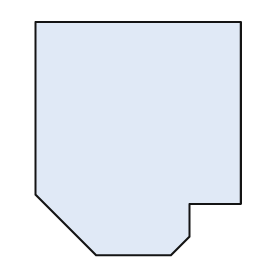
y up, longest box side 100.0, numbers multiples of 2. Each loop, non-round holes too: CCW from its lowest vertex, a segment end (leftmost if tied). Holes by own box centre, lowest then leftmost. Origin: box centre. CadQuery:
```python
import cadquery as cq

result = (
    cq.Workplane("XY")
    .moveTo(-18.0, -50.0)
    .lineTo(14.0, -50.0)
    .lineTo(22.0, -42.0)
    .lineTo(22.0, -28.0)
    .lineTo(44.0, -28.0)
    .lineTo(44.0, 50.0)
    .lineTo(-44.0, 50.0)
    .lineTo(-44.0, -24.0)
    .close()
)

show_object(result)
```